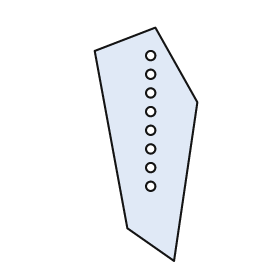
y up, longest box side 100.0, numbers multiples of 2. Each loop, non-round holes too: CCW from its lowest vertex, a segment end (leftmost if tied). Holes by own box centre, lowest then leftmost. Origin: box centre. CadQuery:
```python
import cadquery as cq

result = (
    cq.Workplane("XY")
    .moveTo(12.0, -50.0)
    .lineTo(22.0, 18.0)
    .lineTo(4.0, 50.0)
    .lineTo(-22.0, 40.0)
    .lineTo(-8.0, -36.0)
    .close()
    .moveTo(2.0, -18.0)
    .circle(2.0)
    .moveTo(2.0, -10.0)
    .circle(2.0)
    .moveTo(2.0, -2.0)
    .circle(2.0)
    .moveTo(2.0, 6.0)
    .circle(2.0)
    .moveTo(2.0, 14.0)
    .circle(2.0)
    .moveTo(2.0, 22.0)
    .circle(2.0)
    .moveTo(2.0, 30.0)
    .circle(2.0)
    .moveTo(2.0, 38.0)
    .circle(2.0)
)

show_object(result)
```